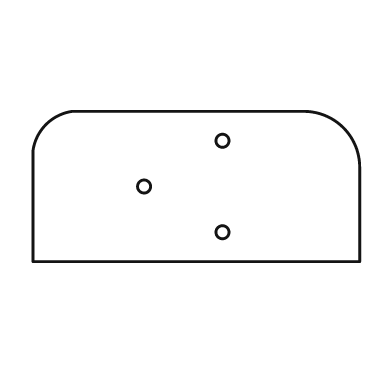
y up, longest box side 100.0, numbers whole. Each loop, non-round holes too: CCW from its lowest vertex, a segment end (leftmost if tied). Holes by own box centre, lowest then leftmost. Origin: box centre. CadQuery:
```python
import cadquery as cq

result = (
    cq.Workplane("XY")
    .moveTo(-50.0, -23.0)
    .lineTo(50.0, -23.0)
    .lineTo(50.0, 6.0)
    .threePointArc((45.0, 18.0), (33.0, 23.0))
    .lineTo(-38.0, 23.0)
    .threePointArc((-46.0, 19.0), (-50.0, 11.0))
    .close()
    .moveTo(8.0, -14.0)
    .circle(2.0)
    .moveTo(-16.0, 0.0)
    .circle(2.0)
    .moveTo(8.0, 14.0)
    .circle(2.0)
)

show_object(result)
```